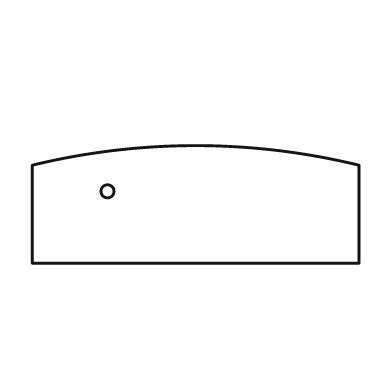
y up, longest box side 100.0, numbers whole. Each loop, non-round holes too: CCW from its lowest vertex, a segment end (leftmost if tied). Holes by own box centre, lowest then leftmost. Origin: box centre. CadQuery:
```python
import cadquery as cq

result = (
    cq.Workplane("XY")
    .moveTo(-50.0, -18.0)
    .lineTo(50.0, -18.0)
    .lineTo(50.0, 12.0)
    .threePointArc((0.0, 18.0), (-50.0, 12.0))
    .close()
    .moveTo(-27.0, 4.0)
    .circle(2.0)
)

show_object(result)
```